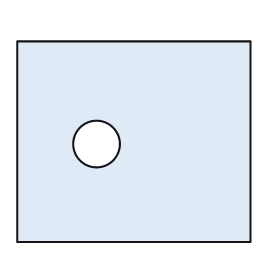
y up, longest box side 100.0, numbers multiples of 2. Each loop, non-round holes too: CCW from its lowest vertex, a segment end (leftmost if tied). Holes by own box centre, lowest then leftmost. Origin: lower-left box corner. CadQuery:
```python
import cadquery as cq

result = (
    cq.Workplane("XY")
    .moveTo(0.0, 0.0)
    .lineTo(100.0, 0.0)
    .lineTo(100.0, 86.0)
    .lineTo(0.0, 86.0)
    .close()
    .moveTo(34.0, 42.0)
    .circle(10.0)
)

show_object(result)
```